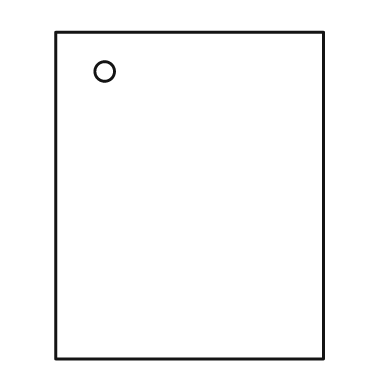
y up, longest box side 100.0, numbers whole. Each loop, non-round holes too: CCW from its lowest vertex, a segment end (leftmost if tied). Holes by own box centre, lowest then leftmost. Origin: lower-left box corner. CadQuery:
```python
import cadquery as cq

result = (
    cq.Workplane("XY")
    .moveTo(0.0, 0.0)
    .lineTo(82.0, 0.0)
    .lineTo(82.0, 100.0)
    .lineTo(0.0, 100.0)
    .close()
    .moveTo(15.0, 88.0)
    .circle(3.0)
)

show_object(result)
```